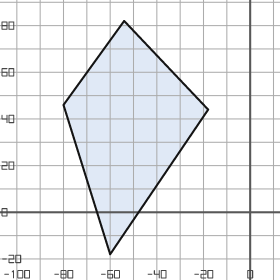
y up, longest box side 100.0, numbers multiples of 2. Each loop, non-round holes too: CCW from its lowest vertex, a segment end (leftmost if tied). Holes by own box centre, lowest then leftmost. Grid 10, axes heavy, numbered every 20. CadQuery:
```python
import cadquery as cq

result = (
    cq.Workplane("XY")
    .moveTo(-60.0, -18.0)
    .lineTo(-18.0, 44.0)
    .lineTo(-54.0, 82.0)
    .lineTo(-80.0, 46.0)
    .close()
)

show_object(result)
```